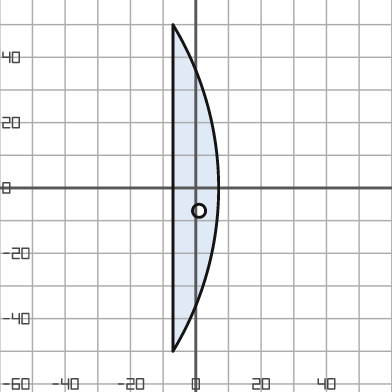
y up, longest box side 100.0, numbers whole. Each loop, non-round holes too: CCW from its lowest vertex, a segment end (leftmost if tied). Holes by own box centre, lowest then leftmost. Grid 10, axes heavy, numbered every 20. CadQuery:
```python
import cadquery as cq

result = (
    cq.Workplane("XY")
    .moveTo(-7.0, -50.0)
    .threePointArc((7.0, 0.0), (-7.0, 50.0))
    .close()
    .moveTo(1.0, -7.0)
    .circle(2.0)
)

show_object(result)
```